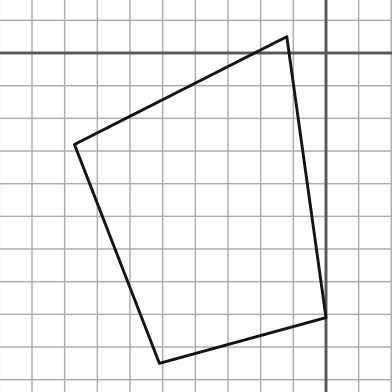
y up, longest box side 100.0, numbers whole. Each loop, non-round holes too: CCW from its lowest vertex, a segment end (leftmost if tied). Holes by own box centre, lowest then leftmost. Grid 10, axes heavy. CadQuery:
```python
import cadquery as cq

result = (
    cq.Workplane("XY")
    .moveTo(-51.0, -95.0)
    .lineTo(0.0, -81.0)
    .lineTo(-12.0, 5.0)
    .lineTo(-77.0, -28.0)
    .close()
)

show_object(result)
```